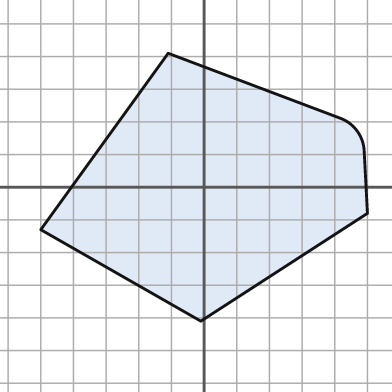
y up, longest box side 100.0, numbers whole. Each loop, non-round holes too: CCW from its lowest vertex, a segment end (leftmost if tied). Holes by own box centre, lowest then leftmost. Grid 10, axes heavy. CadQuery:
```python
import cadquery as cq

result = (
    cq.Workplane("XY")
    .moveTo(-1.0, -41.0)
    .lineTo(50.0, -8.0)
    .lineTo(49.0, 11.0)
    .threePointArc((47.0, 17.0), (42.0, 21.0))
    .lineTo(-11.0, 41.0)
    .lineTo(-50.0, -13.0)
    .close()
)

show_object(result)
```